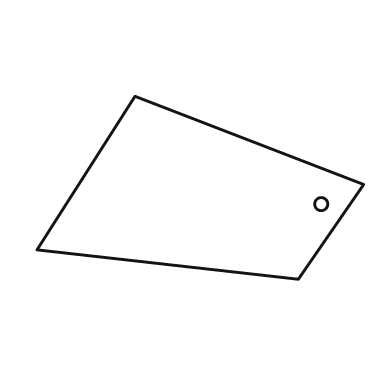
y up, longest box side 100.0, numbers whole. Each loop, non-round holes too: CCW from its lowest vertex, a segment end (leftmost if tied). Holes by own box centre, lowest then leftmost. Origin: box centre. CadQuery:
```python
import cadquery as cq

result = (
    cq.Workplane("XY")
    .moveTo(30.0, -28.0)
    .lineTo(50.0, 1.0)
    .lineTo(-20.0, 28.0)
    .lineTo(-50.0, -19.0)
    .close()
    .moveTo(37.0, -5.0)
    .circle(2.0)
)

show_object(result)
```